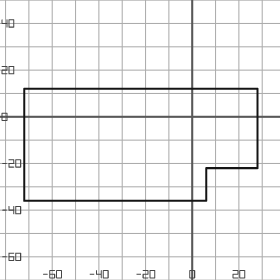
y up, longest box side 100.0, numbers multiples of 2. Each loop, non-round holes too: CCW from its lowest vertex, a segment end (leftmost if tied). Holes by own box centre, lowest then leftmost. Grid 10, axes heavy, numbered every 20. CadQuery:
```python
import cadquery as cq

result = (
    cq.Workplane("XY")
    .moveTo(-72.0, -36.0)
    .lineTo(6.0, -36.0)
    .lineTo(6.0, -22.0)
    .lineTo(28.0, -22.0)
    .lineTo(28.0, 12.0)
    .lineTo(-72.0, 12.0)
    .close()
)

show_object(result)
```